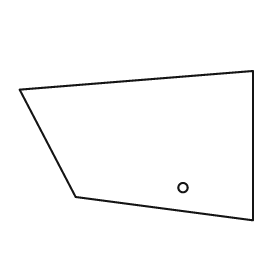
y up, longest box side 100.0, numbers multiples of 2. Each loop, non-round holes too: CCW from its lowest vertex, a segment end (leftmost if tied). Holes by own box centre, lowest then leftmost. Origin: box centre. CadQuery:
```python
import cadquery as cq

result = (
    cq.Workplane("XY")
    .moveTo(50.0, -32.0)
    .lineTo(50.0, 32.0)
    .lineTo(-50.0, 24.0)
    .lineTo(-26.0, -22.0)
    .close()
    .moveTo(20.0, -18.0)
    .circle(2.0)
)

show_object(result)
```